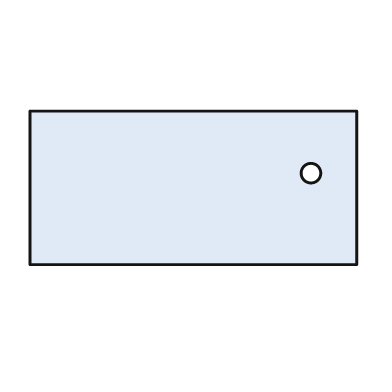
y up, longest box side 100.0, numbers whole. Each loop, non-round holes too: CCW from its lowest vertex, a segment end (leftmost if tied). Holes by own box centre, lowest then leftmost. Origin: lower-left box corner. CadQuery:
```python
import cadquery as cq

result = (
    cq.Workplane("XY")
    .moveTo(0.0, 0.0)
    .lineTo(100.0, 0.0)
    .lineTo(100.0, 47.0)
    .lineTo(0.0, 47.0)
    .close()
    .moveTo(86.0, 28.0)
    .circle(3.0)
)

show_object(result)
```